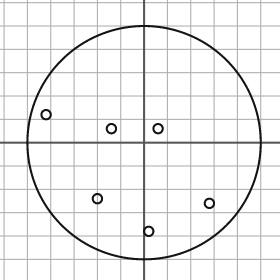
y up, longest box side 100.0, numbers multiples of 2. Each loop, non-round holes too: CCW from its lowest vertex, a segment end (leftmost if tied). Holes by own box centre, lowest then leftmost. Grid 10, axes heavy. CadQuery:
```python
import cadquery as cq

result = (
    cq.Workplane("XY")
    .moveTo(0.0, 0.0)
    .circle(50.0)
    .moveTo(2.0, -38.0)
    .circle(2.0)
    .moveTo(28.0, -26.0)
    .circle(2.0)
    .moveTo(-20.0, -24.0)
    .circle(2.0)
    .moveTo(-14.0, 6.0)
    .circle(2.0)
    .moveTo(6.0, 6.0)
    .circle(2.0)
    .moveTo(-42.0, 12.0)
    .circle(2.0)
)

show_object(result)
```